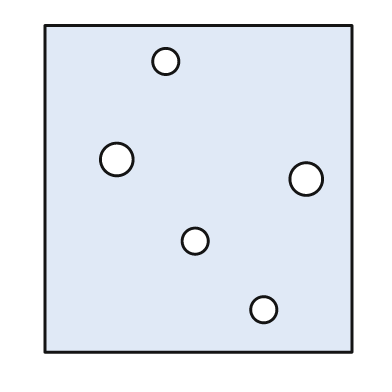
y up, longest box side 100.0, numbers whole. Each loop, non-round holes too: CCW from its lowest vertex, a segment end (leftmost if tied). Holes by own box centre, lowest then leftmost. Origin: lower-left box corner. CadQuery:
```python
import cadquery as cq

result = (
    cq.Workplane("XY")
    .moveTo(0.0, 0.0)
    .lineTo(94.0, 0.0)
    .lineTo(94.0, 100.0)
    .lineTo(0.0, 100.0)
    .close()
    .moveTo(67.0, 13.0)
    .circle(4.0)
    .moveTo(46.0, 34.0)
    .circle(4.0)
    .moveTo(80.0, 53.0)
    .circle(5.0)
    .moveTo(22.0, 59.0)
    .circle(5.0)
    .moveTo(37.0, 89.0)
    .circle(4.0)
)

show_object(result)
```